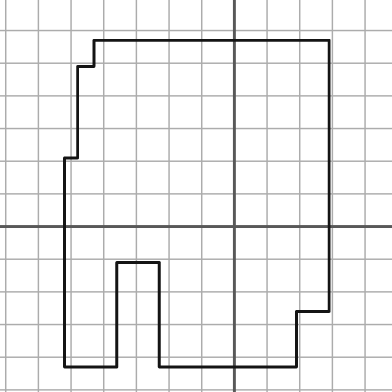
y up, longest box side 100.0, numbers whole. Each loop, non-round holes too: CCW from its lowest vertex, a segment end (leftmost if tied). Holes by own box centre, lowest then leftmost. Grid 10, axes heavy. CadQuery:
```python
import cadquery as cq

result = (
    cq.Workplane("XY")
    .moveTo(-52.0, -43.0)
    .lineTo(-36.0, -43.0)
    .lineTo(-36.0, -11.0)
    .lineTo(-23.0, -11.0)
    .lineTo(-23.0, -43.0)
    .lineTo(19.0, -43.0)
    .lineTo(19.0, -26.0)
    .lineTo(29.0, -26.0)
    .lineTo(29.0, 57.0)
    .lineTo(-43.0, 57.0)
    .lineTo(-43.0, 49.0)
    .lineTo(-48.0, 49.0)
    .lineTo(-48.0, 21.0)
    .lineTo(-52.0, 21.0)
    .close()
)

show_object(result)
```